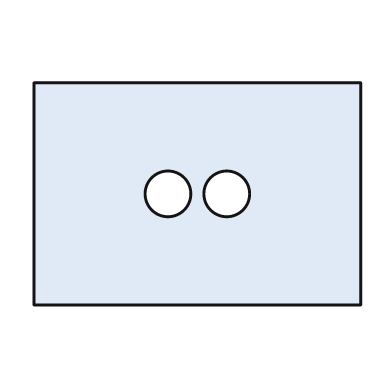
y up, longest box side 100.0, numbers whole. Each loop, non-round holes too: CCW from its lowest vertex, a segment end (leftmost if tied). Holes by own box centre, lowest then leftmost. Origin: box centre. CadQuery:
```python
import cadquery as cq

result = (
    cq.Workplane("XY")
    .moveTo(-50.0, -34.0)
    .lineTo(50.0, -34.0)
    .lineTo(50.0, 34.0)
    .lineTo(-50.0, 34.0)
    .close()
    .moveTo(-9.0, 0.0)
    .circle(7.0)
    .moveTo(9.0, 0.0)
    .circle(7.0)
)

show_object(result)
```